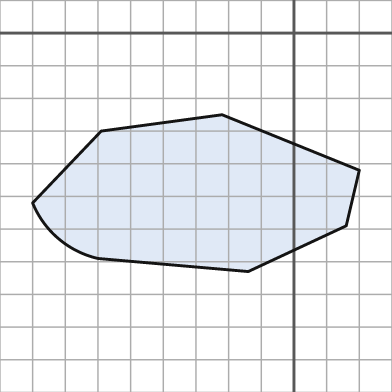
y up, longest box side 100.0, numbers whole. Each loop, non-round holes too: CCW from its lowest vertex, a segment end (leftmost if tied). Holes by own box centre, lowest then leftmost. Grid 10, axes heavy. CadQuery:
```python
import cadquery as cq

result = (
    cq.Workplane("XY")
    .moveTo(-14.0, -73.0)
    .lineTo(16.0, -59.0)
    .lineTo(20.0, -42.0)
    .lineTo(-22.0, -25.0)
    .lineTo(-59.0, -30.0)
    .lineTo(-80.0, -52.0)
    .threePointArc((-72.0, -63.0), (-60.0, -69.0))
    .close()
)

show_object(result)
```